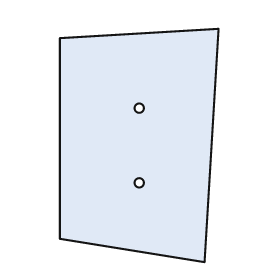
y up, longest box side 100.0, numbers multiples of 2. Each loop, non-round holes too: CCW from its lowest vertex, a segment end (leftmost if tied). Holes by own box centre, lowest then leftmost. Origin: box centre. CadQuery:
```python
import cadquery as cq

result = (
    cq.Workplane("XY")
    .moveTo(28.0, -50.0)
    .lineTo(34.0, 50.0)
    .lineTo(-34.0, 46.0)
    .lineTo(-34.0, -40.0)
    .close()
    .moveTo(0.0, -16.0)
    .circle(2.0)
    .moveTo(0.0, 16.0)
    .circle(2.0)
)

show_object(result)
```